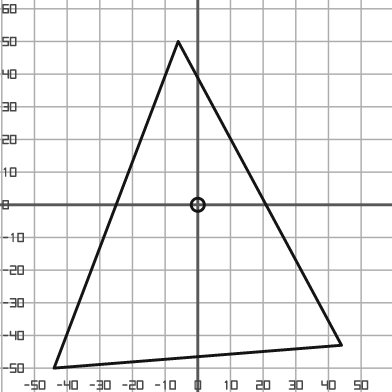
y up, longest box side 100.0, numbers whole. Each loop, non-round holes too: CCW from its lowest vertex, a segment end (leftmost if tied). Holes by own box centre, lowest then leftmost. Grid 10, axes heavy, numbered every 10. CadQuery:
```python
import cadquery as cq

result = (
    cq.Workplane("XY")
    .moveTo(-44.0, -50.0)
    .lineTo(44.0, -43.0)
    .lineTo(-6.0, 50.0)
    .close()
    .moveTo(0.0, 0.0)
    .circle(2.0)
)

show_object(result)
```